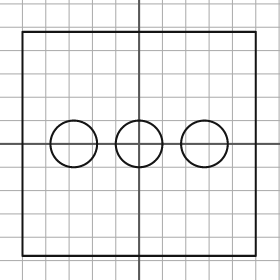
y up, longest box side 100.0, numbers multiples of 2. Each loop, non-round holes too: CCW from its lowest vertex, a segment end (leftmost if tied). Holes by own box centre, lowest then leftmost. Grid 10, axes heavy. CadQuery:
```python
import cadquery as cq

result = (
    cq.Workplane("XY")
    .moveTo(-50.0, -48.0)
    .lineTo(50.0, -48.0)
    .lineTo(50.0, 48.0)
    .lineTo(-50.0, 48.0)
    .close()
    .moveTo(-28.0, 0.0)
    .circle(10.0)
    .moveTo(0.0, 0.0)
    .circle(10.0)
    .moveTo(28.0, 0.0)
    .circle(10.0)
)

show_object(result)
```